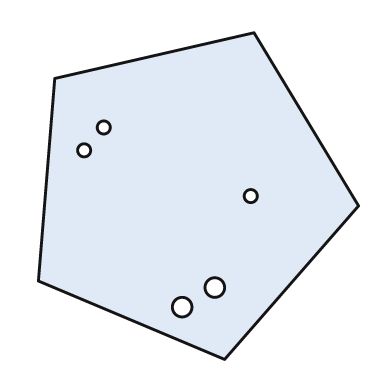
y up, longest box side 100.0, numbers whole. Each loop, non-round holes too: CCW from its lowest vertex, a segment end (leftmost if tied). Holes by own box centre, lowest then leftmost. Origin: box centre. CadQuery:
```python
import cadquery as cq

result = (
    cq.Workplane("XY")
    .moveTo(8.0, -50.0)
    .lineTo(49.0, -3.0)
    .lineTo(17.0, 50.0)
    .lineTo(-44.0, 36.0)
    .lineTo(-49.0, -26.0)
    .close()
    .moveTo(-5.0, -34.0)
    .circle(3.0)
    .moveTo(5.0, -28.0)
    .circle(3.0)
    .moveTo(16.0, 0.0)
    .circle(2.0)
    .moveTo(-35.0, 14.0)
    .circle(2.0)
    .moveTo(-29.0, 21.0)
    .circle(2.0)
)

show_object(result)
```